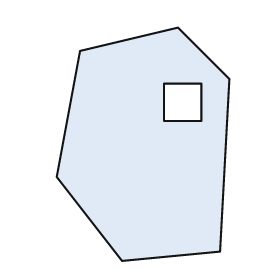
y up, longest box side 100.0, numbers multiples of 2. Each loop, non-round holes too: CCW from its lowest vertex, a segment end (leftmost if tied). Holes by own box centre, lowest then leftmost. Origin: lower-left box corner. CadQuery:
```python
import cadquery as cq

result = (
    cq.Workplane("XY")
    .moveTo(28.0, 0.0)
    .lineTo(70.0, 4.0)
    .lineTo(74.0, 78.0)
    .lineTo(52.0, 100.0)
    .lineTo(10.0, 90.0)
    .lineTo(0.0, 36.0)
    .close()
    .moveTo(46.0, 60.0)
    .lineTo(62.0, 60.0)
    .lineTo(62.0, 76.0)
    .lineTo(46.0, 76.0)
    .close()
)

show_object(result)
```